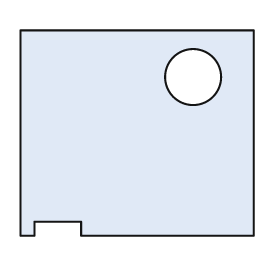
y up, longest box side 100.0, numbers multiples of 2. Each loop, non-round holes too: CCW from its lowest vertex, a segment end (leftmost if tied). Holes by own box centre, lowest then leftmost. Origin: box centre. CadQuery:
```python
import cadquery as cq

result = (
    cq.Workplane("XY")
    .moveTo(-50.0, -44.0)
    .lineTo(-44.0, -44.0)
    .lineTo(-44.0, -38.0)
    .lineTo(-24.0, -38.0)
    .lineTo(-24.0, -44.0)
    .lineTo(50.0, -44.0)
    .lineTo(50.0, 44.0)
    .lineTo(-50.0, 44.0)
    .close()
    .moveTo(24.0, 24.0)
    .circle(12.0)
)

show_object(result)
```